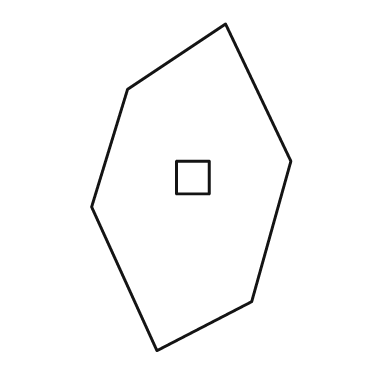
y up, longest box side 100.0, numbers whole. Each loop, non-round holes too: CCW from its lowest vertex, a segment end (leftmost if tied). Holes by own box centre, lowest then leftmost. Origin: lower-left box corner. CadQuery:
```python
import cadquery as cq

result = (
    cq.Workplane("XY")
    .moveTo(20.0, 0.0)
    .lineTo(49.0, 15.0)
    .lineTo(61.0, 58.0)
    .lineTo(41.0, 100.0)
    .lineTo(11.0, 80.0)
    .lineTo(0.0, 44.0)
    .close()
    .moveTo(26.0, 48.0)
    .lineTo(36.0, 48.0)
    .lineTo(36.0, 58.0)
    .lineTo(26.0, 58.0)
    .close()
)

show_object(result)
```